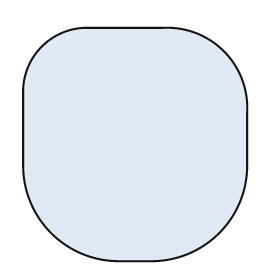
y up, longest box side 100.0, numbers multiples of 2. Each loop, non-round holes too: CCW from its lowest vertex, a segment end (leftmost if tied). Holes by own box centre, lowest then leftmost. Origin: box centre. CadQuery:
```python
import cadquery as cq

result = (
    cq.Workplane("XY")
    .moveTo(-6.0, -50.0)
    .lineTo(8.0, -50.0)
    .threePointArc((36.0, -38.0), (48.0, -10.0))
    .lineTo(48.0, 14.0)
    .threePointArc((38.0, 40.0), (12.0, 50.0))
    .lineTo(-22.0, 50.0)
    .threePointArc((-40.0, 42.0), (-48.0, 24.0))
    .lineTo(-48.0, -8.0)
    .threePointArc((-36.0, -38.0), (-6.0, -50.0))
    .close()
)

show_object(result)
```